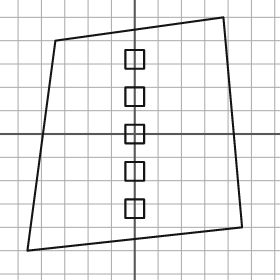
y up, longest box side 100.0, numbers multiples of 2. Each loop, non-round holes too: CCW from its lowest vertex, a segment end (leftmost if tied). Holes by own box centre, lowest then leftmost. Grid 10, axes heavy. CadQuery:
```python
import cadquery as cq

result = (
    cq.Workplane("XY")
    .moveTo(-46.0, -50.0)
    .lineTo(46.0, -40.0)
    .lineTo(38.0, 50.0)
    .lineTo(-34.0, 40.0)
    .close()
    .moveTo(-4.0, -36.0)
    .lineTo(4.0, -36.0)
    .lineTo(4.0, -28.0)
    .lineTo(-4.0, -28.0)
    .close()
    .moveTo(-4.0, -20.0)
    .lineTo(4.0, -20.0)
    .lineTo(4.0, -12.0)
    .lineTo(-4.0, -12.0)
    .close()
    .moveTo(-4.0, -4.0)
    .lineTo(4.0, -4.0)
    .lineTo(4.0, 4.0)
    .lineTo(-4.0, 4.0)
    .close()
    .moveTo(-4.0, 12.0)
    .lineTo(4.0, 12.0)
    .lineTo(4.0, 20.0)
    .lineTo(-4.0, 20.0)
    .close()
    .moveTo(-4.0, 28.0)
    .lineTo(4.0, 28.0)
    .lineTo(4.0, 36.0)
    .lineTo(-4.0, 36.0)
    .close()
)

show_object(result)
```